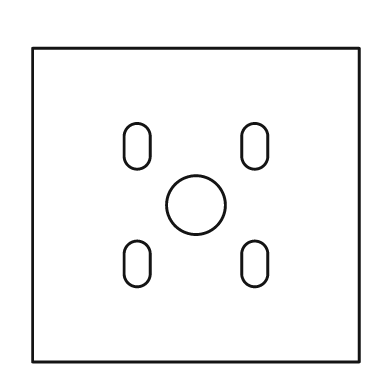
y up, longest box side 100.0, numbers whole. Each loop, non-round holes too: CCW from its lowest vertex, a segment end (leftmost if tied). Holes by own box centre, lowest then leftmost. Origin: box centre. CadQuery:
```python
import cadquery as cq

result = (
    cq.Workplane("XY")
    .moveTo(-50.0, -48.0)
    .lineTo(50.0, -48.0)
    .lineTo(50.0, 48.0)
    .lineTo(-50.0, 48.0)
    .close()
    .moveTo(-22.0, -21.0)
    .threePointArc((-18.0, -25.0), (-14.0, -21.0))
    .lineTo(-14.0, -15.0)
    .threePointArc((-18.0, -11.0), (-22.0, -15.0))
    .close()
    .moveTo(14.0, -21.0)
    .threePointArc((18.0, -25.0), (22.0, -21.0))
    .lineTo(22.0, -15.0)
    .threePointArc((18.0, -11.0), (14.0, -15.0))
    .close()
    .moveTo(0.0, 0.0)
    .circle(9.0)
    .moveTo(-22.0, 15.0)
    .threePointArc((-18.0, 11.0), (-14.0, 15.0))
    .lineTo(-14.0, 21.0)
    .threePointArc((-18.0, 25.0), (-22.0, 21.0))
    .close()
    .moveTo(14.0, 15.0)
    .threePointArc((18.0, 11.0), (22.0, 15.0))
    .lineTo(22.0, 21.0)
    .threePointArc((18.0, 25.0), (14.0, 21.0))
    .close()
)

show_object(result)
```